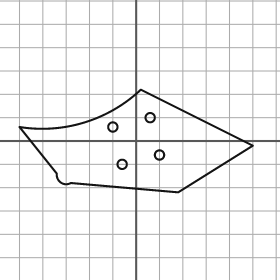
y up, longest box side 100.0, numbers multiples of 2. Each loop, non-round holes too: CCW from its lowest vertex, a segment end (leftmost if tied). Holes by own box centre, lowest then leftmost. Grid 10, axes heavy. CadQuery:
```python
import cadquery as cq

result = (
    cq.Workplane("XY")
    .moveTo(18.0, -22.0)
    .lineTo(50.0, -2.0)
    .lineTo(2.0, 22.0)
    .threePointArc((-22.0, 8.0), (-50.0, 6.0))
    .lineTo(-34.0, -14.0)
    .threePointArc((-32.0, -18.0), (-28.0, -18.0))
    .close()
    .moveTo(-6.0, -10.0)
    .circle(2.0)
    .moveTo(10.0, -6.0)
    .circle(2.0)
    .moveTo(-10.0, 6.0)
    .circle(2.0)
    .moveTo(6.0, 10.0)
    .circle(2.0)
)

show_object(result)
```